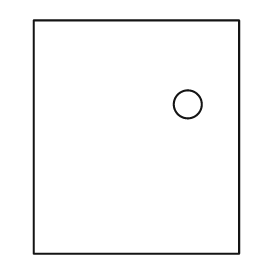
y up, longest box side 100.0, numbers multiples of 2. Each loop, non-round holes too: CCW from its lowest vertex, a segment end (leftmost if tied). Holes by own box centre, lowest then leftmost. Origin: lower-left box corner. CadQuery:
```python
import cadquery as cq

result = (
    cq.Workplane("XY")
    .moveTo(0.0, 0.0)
    .lineTo(88.0, 0.0)
    .lineTo(88.0, 100.0)
    .lineTo(0.0, 100.0)
    .close()
    .moveTo(66.0, 64.0)
    .circle(6.0)
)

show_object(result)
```